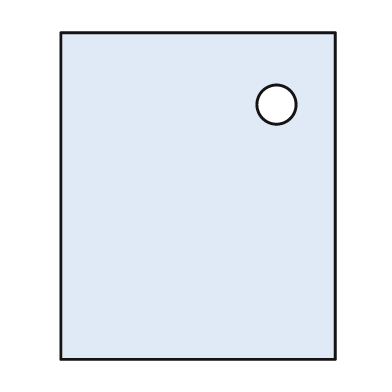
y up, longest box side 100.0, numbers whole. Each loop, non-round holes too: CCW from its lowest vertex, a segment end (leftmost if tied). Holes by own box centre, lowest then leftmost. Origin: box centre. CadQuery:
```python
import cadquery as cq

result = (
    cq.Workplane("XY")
    .moveTo(-42.0, -50.0)
    .lineTo(42.0, -50.0)
    .lineTo(42.0, 50.0)
    .lineTo(-42.0, 50.0)
    .close()
    .moveTo(24.0, 28.0)
    .circle(6.0)
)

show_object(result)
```